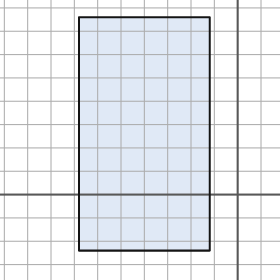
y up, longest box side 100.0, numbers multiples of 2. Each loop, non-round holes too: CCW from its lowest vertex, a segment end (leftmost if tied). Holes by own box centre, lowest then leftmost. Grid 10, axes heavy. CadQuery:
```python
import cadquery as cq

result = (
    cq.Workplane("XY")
    .moveTo(-68.0, -24.0)
    .lineTo(-12.0, -24.0)
    .lineTo(-12.0, 76.0)
    .lineTo(-68.0, 76.0)
    .close()
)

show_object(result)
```